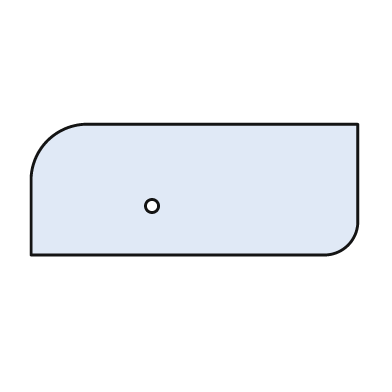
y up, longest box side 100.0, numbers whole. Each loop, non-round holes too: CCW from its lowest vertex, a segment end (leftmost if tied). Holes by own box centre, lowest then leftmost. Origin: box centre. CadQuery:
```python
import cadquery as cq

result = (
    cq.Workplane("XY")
    .moveTo(-50.0, -20.0)
    .lineTo(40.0, -20.0)
    .threePointArc((47.0, -17.0), (50.0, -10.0))
    .lineTo(50.0, 20.0)
    .lineTo(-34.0, 20.0)
    .threePointArc((-45.0, 15.0), (-50.0, 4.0))
    .close()
    .moveTo(-13.0, -5.0)
    .circle(2.0)
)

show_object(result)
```